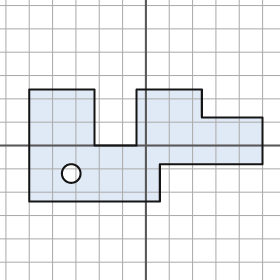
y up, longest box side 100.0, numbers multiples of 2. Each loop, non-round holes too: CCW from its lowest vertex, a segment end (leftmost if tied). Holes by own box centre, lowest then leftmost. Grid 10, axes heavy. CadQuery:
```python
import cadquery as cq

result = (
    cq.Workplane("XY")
    .moveTo(-50.0, -24.0)
    .lineTo(6.0, -24.0)
    .lineTo(6.0, -8.0)
    .lineTo(50.0, -8.0)
    .lineTo(50.0, 12.0)
    .lineTo(24.0, 12.0)
    .lineTo(24.0, 24.0)
    .lineTo(-4.0, 24.0)
    .lineTo(-4.0, 0.0)
    .lineTo(-22.0, 0.0)
    .lineTo(-22.0, 24.0)
    .lineTo(-50.0, 24.0)
    .close()
    .moveTo(-32.0, -12.0)
    .circle(4.0)
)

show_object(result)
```